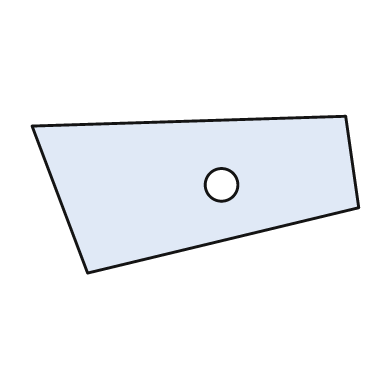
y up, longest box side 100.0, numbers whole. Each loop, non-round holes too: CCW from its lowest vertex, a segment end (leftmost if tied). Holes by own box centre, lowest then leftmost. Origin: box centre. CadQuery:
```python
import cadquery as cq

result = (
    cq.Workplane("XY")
    .moveTo(-33.0, -24.0)
    .lineTo(50.0, -4.0)
    .lineTo(46.0, 24.0)
    .lineTo(-50.0, 21.0)
    .close()
    .moveTo(8.0, 3.0)
    .circle(5.0)
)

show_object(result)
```